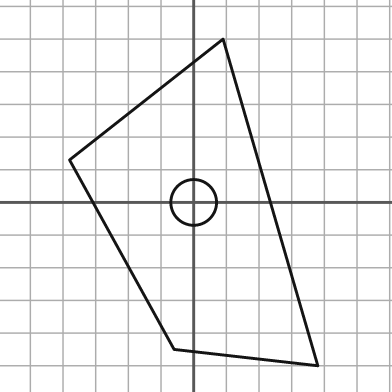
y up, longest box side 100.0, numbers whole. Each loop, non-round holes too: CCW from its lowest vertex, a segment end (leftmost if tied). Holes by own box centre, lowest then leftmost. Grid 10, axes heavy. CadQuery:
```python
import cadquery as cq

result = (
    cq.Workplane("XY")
    .moveTo(38.0, -50.0)
    .lineTo(9.0, 50.0)
    .lineTo(-38.0, 13.0)
    .lineTo(-6.0, -45.0)
    .close()
    .moveTo(0.0, 0.0)
    .circle(7.0)
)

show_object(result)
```